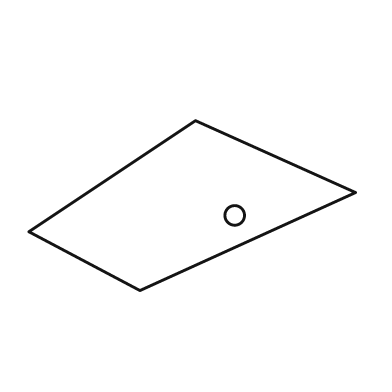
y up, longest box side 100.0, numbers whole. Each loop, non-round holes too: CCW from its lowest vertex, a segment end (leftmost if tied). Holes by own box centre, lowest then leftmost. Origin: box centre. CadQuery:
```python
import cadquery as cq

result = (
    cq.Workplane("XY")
    .moveTo(-16.0, -26.0)
    .lineTo(50.0, 4.0)
    .lineTo(1.0, 26.0)
    .lineTo(-50.0, -8.0)
    .close()
    .moveTo(13.0, -3.0)
    .circle(3.0)
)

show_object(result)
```